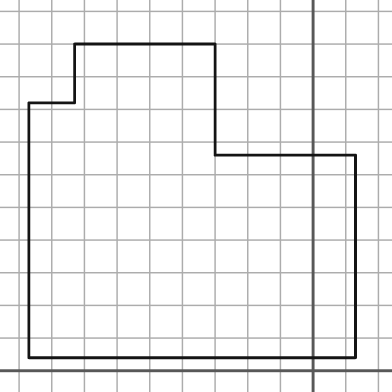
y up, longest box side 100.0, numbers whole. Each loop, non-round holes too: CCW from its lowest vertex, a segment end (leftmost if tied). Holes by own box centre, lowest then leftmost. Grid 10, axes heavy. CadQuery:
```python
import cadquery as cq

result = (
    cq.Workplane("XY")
    .moveTo(-87.0, 4.0)
    .lineTo(13.0, 4.0)
    .lineTo(13.0, 66.0)
    .lineTo(-30.0, 66.0)
    .lineTo(-30.0, 100.0)
    .lineTo(-73.0, 100.0)
    .lineTo(-73.0, 82.0)
    .lineTo(-87.0, 82.0)
    .close()
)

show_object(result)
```